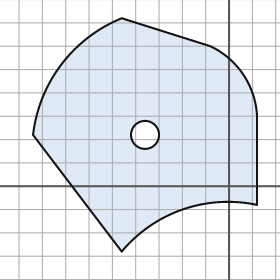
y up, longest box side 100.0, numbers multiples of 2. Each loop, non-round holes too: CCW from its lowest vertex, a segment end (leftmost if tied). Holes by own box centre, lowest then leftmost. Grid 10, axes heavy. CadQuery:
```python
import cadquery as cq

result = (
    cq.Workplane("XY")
    .moveTo(-46.0, -28.0)
    .threePointArc((-20.0, -10.0), (12.0, -8.0))
    .lineTo(12.0, 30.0)
    .threePointArc((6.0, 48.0), (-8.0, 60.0))
    .lineTo(-46.0, 72.0)
    .threePointArc((-72.0, 52.0), (-84.0, 22.0))
    .close()
    .moveTo(-36.0, 22.0)
    .circle(6.0)
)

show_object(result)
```